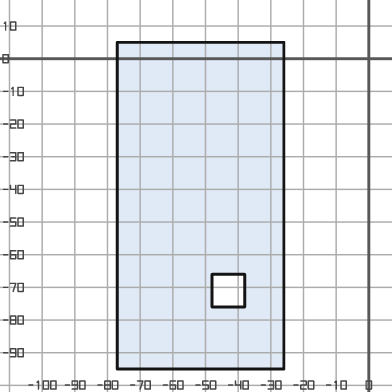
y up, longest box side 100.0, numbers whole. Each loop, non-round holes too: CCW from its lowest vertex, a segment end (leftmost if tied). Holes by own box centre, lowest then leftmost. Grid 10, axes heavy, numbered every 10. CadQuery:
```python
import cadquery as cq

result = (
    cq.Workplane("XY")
    .moveTo(-77.0, -95.0)
    .lineTo(-26.0, -95.0)
    .lineTo(-26.0, 5.0)
    .lineTo(-77.0, 5.0)
    .close()
    .moveTo(-48.0, -76.0)
    .lineTo(-38.0, -76.0)
    .lineTo(-38.0, -66.0)
    .lineTo(-48.0, -66.0)
    .close()
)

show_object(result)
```